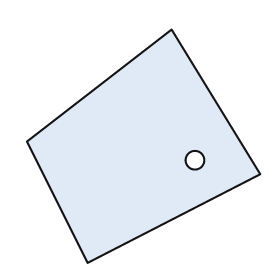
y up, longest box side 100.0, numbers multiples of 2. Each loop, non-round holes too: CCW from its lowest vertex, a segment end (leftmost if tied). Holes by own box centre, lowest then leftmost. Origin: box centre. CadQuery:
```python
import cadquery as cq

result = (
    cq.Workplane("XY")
    .moveTo(-24.0, -50.0)
    .lineTo(50.0, -12.0)
    .lineTo(12.0, 50.0)
    .lineTo(-50.0, 2.0)
    .close()
    .moveTo(22.0, -6.0)
    .circle(4.0)
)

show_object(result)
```